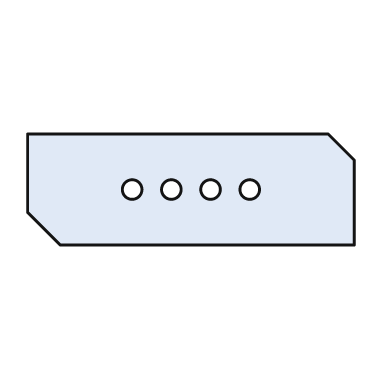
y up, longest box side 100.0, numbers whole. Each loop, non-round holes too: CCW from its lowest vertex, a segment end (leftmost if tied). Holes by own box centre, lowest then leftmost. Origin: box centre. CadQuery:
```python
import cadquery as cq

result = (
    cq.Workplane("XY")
    .moveTo(-40.0, -17.0)
    .lineTo(50.0, -17.0)
    .lineTo(50.0, 9.0)
    .lineTo(42.0, 17.0)
    .lineTo(-50.0, 17.0)
    .lineTo(-50.0, -7.0)
    .close()
    .moveTo(-18.0, 0.0)
    .circle(3.0)
    .moveTo(-6.0, 0.0)
    .circle(3.0)
    .moveTo(6.0, 0.0)
    .circle(3.0)
    .moveTo(18.0, 0.0)
    .circle(3.0)
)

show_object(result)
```